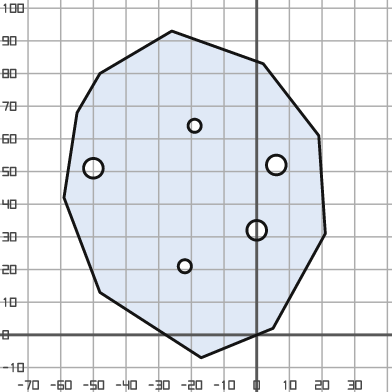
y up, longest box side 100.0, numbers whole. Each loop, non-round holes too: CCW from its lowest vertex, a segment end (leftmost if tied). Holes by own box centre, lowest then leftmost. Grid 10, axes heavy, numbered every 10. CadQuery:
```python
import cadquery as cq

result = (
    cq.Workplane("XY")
    .moveTo(-17.0, -7.0)
    .lineTo(5.0, 2.0)
    .lineTo(21.0, 31.0)
    .lineTo(19.0, 61.0)
    .lineTo(2.0, 83.0)
    .lineTo(-26.0, 93.0)
    .lineTo(-48.0, 80.0)
    .lineTo(-55.0, 68.0)
    .lineTo(-59.0, 42.0)
    .lineTo(-48.0, 13.0)
    .close()
    .moveTo(-22.0, 21.0)
    .circle(2.0)
    .moveTo(0.0, 32.0)
    .circle(3.0)
    .moveTo(-50.0, 51.0)
    .circle(3.0)
    .moveTo(6.0, 52.0)
    .circle(3.0)
    .moveTo(-19.0, 64.0)
    .circle(2.0)
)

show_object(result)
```